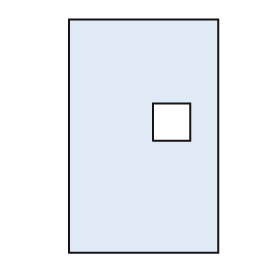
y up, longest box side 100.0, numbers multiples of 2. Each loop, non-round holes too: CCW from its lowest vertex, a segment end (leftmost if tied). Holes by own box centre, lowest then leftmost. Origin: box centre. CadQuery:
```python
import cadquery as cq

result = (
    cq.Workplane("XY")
    .moveTo(-32.0, -50.0)
    .lineTo(32.0, -50.0)
    .lineTo(32.0, 50.0)
    .lineTo(-32.0, 50.0)
    .close()
    .moveTo(4.0, -2.0)
    .lineTo(20.0, -2.0)
    .lineTo(20.0, 14.0)
    .lineTo(4.0, 14.0)
    .close()
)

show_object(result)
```